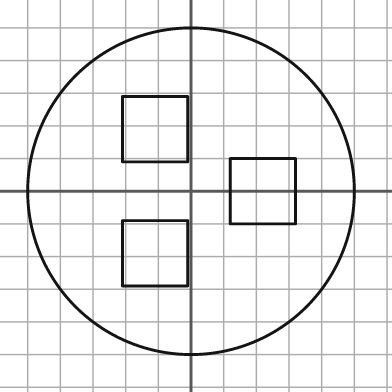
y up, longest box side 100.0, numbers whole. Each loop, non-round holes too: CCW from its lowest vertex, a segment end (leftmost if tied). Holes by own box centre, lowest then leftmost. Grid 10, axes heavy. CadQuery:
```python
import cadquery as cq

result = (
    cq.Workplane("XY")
    .moveTo(0.0, 0.0)
    .circle(50.0)
    .moveTo(-21.0, -29.0)
    .lineTo(-1.0, -29.0)
    .lineTo(-1.0, -9.0)
    .lineTo(-21.0, -9.0)
    .close()
    .moveTo(12.0, -10.0)
    .lineTo(32.0, -10.0)
    .lineTo(32.0, 10.0)
    .lineTo(12.0, 10.0)
    .close()
    .moveTo(-21.0, 9.0)
    .lineTo(-1.0, 9.0)
    .lineTo(-1.0, 29.0)
    .lineTo(-21.0, 29.0)
    .close()
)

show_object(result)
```